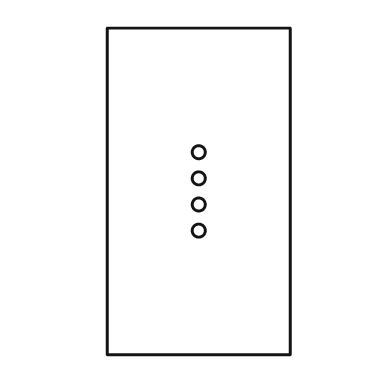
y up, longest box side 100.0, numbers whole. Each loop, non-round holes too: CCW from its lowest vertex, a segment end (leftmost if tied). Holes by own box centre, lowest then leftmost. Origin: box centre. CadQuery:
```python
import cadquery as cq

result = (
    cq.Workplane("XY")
    .moveTo(-28.0, -50.0)
    .lineTo(28.0, -50.0)
    .lineTo(28.0, 50.0)
    .lineTo(-28.0, 50.0)
    .close()
    .moveTo(0.0, -12.0)
    .circle(2.0)
    .moveTo(0.0, -4.0)
    .circle(2.0)
    .moveTo(0.0, 4.0)
    .circle(2.0)
    .moveTo(0.0, 12.0)
    .circle(2.0)
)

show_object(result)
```